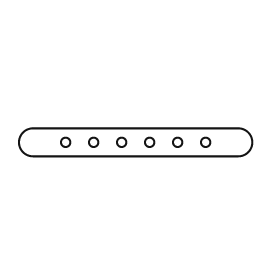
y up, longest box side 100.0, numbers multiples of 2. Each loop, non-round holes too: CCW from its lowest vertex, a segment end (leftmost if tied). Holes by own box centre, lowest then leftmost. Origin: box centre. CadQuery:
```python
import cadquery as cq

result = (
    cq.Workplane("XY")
    .moveTo(-44.0, -6.0)
    .lineTo(44.0, -6.0)
    .threePointArc((50.0, 0.0), (44.0, 6.0))
    .lineTo(-44.0, 6.0)
    .threePointArc((-50.0, 0.0), (-44.0, -6.0))
    .close()
    .moveTo(-30.0, 0.0)
    .circle(2.0)
    .moveTo(-18.0, 0.0)
    .circle(2.0)
    .moveTo(-6.0, 0.0)
    .circle(2.0)
    .moveTo(6.0, 0.0)
    .circle(2.0)
    .moveTo(18.0, 0.0)
    .circle(2.0)
    .moveTo(30.0, 0.0)
    .circle(2.0)
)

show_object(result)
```